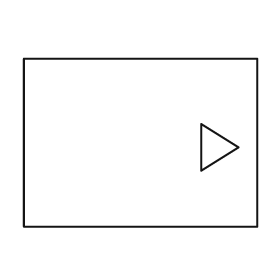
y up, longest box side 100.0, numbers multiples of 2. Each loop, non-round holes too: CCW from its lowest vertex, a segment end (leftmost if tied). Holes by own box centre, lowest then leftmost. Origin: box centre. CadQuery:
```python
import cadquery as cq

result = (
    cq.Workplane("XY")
    .moveTo(-50.0, -36.0)
    .lineTo(50.0, -36.0)
    .lineTo(50.0, 36.0)
    .lineTo(-50.0, 36.0)
    .close()
    .moveTo(26.0, -12.0)
    .lineTo(42.0, -2.0)
    .lineTo(26.0, 8.0)
    .close()
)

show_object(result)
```